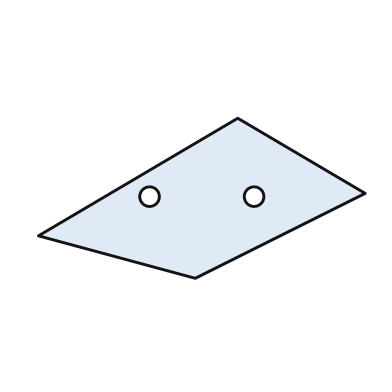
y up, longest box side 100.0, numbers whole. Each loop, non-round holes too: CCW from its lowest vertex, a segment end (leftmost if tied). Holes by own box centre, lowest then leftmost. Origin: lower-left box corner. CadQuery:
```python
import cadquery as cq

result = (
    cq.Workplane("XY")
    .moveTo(48.0, 0.0)
    .lineTo(100.0, 26.0)
    .lineTo(61.0, 49.0)
    .lineTo(0.0, 13.0)
    .close()
    .moveTo(34.0, 25.0)
    .circle(3.0)
    .moveTo(66.0, 25.0)
    .circle(3.0)
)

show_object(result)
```